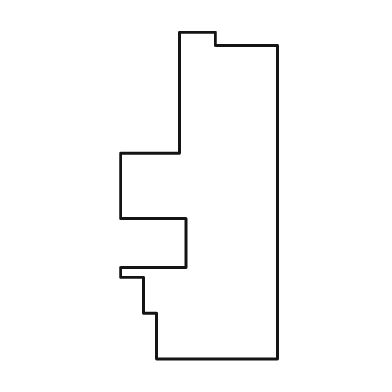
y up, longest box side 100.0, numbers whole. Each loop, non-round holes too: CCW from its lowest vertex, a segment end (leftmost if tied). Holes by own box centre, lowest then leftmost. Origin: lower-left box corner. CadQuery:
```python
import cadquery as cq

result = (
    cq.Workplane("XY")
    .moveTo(11.0, 0.0)
    .lineTo(48.0, 0.0)
    .lineTo(48.0, 96.0)
    .lineTo(29.0, 96.0)
    .lineTo(29.0, 100.0)
    .lineTo(18.0, 100.0)
    .lineTo(18.0, 63.0)
    .lineTo(0.0, 63.0)
    .lineTo(0.0, 43.0)
    .lineTo(20.0, 43.0)
    .lineTo(20.0, 28.0)
    .lineTo(0.0, 28.0)
    .lineTo(0.0, 25.0)
    .lineTo(7.0, 25.0)
    .lineTo(7.0, 14.0)
    .lineTo(11.0, 14.0)
    .close()
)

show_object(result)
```